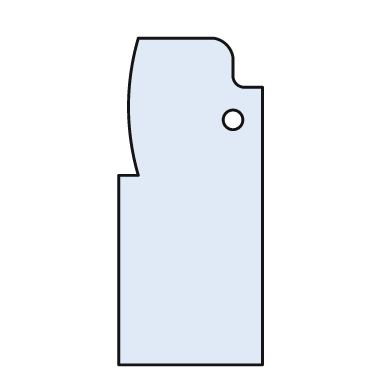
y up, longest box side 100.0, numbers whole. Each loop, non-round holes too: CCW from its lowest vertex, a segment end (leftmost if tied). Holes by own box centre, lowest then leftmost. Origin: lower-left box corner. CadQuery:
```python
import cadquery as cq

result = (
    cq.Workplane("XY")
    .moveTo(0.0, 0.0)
    .lineTo(44.0, 0.0)
    .lineTo(44.0, 85.0)
    .lineTo(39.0, 85.0)
    .threePointArc((36.0, 86.0), (35.0, 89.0))
    .lineTo(35.0, 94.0)
    .threePointArc((33.0, 98.0), (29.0, 100.0))
    .lineTo(6.0, 100.0)
    .threePointArc((3.0, 79.0), (6.0, 58.0))
    .lineTo(0.0, 58.0)
    .close()
    .moveTo(35.0, 75.0)
    .circle(3.0)
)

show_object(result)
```